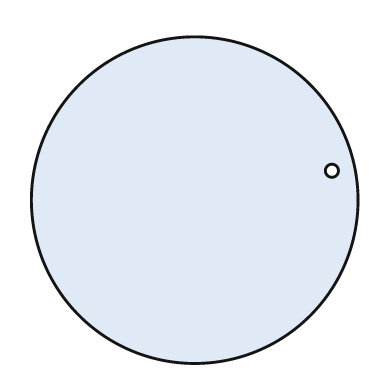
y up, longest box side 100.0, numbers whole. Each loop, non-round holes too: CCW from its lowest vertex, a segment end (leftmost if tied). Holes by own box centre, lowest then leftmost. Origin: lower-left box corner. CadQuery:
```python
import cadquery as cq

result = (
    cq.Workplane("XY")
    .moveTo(50.0, 50.0)
    .circle(50.0)
    .moveTo(92.0, 59.0)
    .circle(2.0)
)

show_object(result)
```